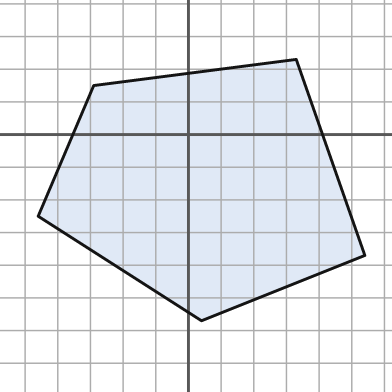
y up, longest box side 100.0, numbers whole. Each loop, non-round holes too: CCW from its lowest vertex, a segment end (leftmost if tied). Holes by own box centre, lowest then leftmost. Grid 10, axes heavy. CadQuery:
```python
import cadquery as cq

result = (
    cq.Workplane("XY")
    .moveTo(4.0, -57.0)
    .lineTo(54.0, -37.0)
    .lineTo(33.0, 23.0)
    .lineTo(-29.0, 15.0)
    .lineTo(-46.0, -25.0)
    .close()
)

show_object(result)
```